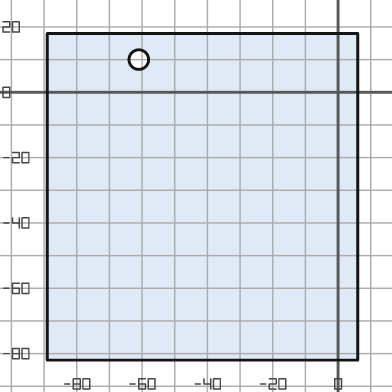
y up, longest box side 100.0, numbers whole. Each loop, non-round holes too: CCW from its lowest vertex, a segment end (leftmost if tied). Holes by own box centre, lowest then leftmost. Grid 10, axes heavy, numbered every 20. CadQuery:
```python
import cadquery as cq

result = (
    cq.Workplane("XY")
    .moveTo(-89.0, -82.0)
    .lineTo(6.0, -82.0)
    .lineTo(6.0, 18.0)
    .lineTo(-89.0, 18.0)
    .close()
    .moveTo(-61.0, 10.0)
    .circle(3.0)
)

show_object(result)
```